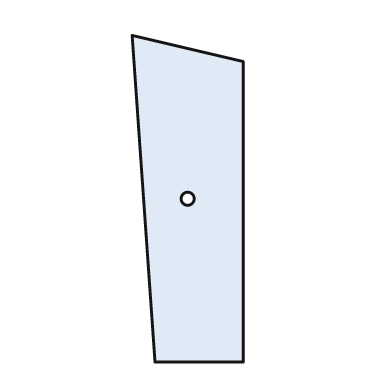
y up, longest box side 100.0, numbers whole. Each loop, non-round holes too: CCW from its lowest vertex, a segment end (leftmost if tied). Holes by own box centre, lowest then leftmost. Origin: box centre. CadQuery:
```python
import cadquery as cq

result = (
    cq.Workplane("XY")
    .moveTo(-10.0, -50.0)
    .lineTo(17.0, -50.0)
    .lineTo(17.0, 42.0)
    .lineTo(-17.0, 50.0)
    .close()
    .moveTo(0.0, 0.0)
    .circle(2.0)
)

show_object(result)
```